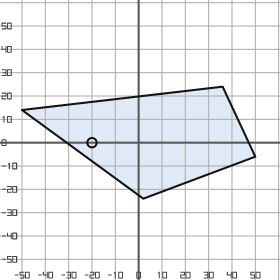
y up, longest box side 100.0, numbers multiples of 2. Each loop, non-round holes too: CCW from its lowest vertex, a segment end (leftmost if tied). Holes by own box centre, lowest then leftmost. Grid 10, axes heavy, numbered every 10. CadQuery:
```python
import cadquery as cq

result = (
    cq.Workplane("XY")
    .moveTo(2.0, -24.0)
    .lineTo(50.0, -6.0)
    .lineTo(36.0, 24.0)
    .lineTo(-50.0, 14.0)
    .close()
    .moveTo(-20.0, 0.0)
    .circle(2.0)
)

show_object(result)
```